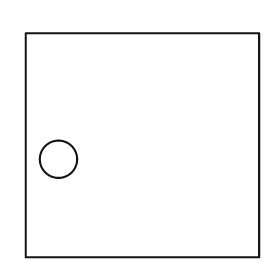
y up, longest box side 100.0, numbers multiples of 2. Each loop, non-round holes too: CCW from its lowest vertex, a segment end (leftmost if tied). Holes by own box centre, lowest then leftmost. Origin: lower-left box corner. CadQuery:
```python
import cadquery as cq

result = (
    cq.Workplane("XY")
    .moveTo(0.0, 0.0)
    .lineTo(100.0, 0.0)
    .lineTo(100.0, 96.0)
    .lineTo(0.0, 96.0)
    .close()
    .moveTo(14.0, 42.0)
    .circle(8.0)
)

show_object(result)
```